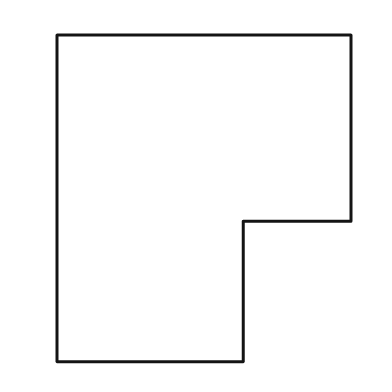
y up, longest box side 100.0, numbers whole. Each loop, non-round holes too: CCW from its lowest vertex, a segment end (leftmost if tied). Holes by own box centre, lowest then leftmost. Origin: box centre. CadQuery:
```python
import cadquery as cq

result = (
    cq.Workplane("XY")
    .moveTo(-45.0, -50.0)
    .lineTo(12.0, -50.0)
    .lineTo(12.0, -7.0)
    .lineTo(45.0, -7.0)
    .lineTo(45.0, 50.0)
    .lineTo(-45.0, 50.0)
    .close()
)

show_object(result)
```